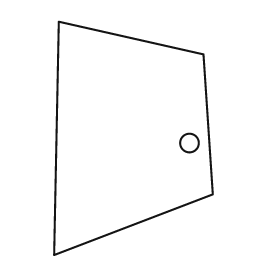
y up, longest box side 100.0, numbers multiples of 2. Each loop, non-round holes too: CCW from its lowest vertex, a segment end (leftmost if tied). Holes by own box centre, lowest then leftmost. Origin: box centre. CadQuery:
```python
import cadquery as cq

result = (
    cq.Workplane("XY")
    .moveTo(-34.0, -50.0)
    .lineTo(34.0, -24.0)
    .lineTo(30.0, 36.0)
    .lineTo(-32.0, 50.0)
    .close()
    .moveTo(24.0, -2.0)
    .circle(4.0)
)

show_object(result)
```